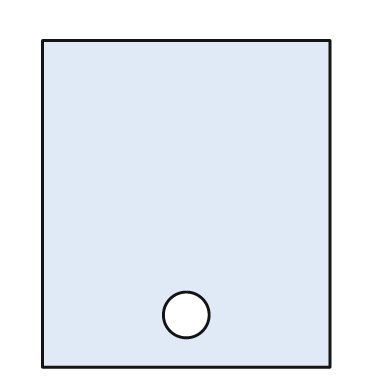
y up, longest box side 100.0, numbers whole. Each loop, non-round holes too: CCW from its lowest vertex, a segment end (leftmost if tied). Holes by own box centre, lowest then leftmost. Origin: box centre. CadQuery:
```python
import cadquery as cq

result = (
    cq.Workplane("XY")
    .moveTo(-44.0, -50.0)
    .lineTo(44.0, -50.0)
    .lineTo(44.0, 50.0)
    .lineTo(-44.0, 50.0)
    .close()
    .moveTo(0.0, -34.0)
    .circle(7.0)
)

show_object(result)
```